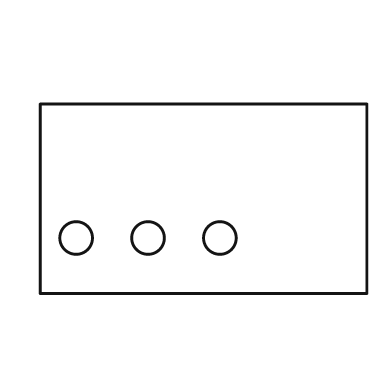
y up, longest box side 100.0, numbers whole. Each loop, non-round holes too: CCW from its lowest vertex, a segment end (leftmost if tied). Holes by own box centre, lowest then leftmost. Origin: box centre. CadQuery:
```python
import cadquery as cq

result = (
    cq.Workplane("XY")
    .moveTo(-50.0, -29.0)
    .lineTo(50.0, -29.0)
    .lineTo(50.0, 29.0)
    .lineTo(-50.0, 29.0)
    .close()
    .moveTo(-39.0, -12.0)
    .circle(5.0)
    .moveTo(-17.0, -12.0)
    .circle(5.0)
    .moveTo(5.0, -12.0)
    .circle(5.0)
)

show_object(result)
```